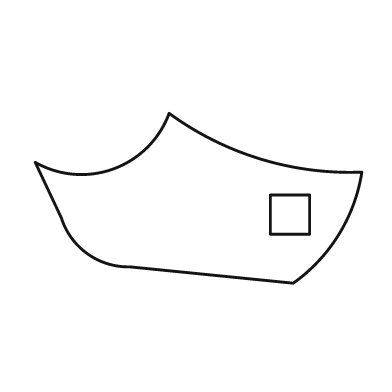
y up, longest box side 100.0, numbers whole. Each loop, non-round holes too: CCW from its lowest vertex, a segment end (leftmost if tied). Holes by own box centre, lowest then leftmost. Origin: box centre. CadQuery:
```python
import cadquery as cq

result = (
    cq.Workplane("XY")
    .moveTo(29.0, -26.0)
    .threePointArc((43.0, -11.0), (50.0, 8.0))
    .threePointArc((19.0, 12.0), (-9.0, 26.0))
    .threePointArc((-26.0, 9.0), (-50.0, 11.0))
    .lineTo(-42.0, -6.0)
    .threePointArc((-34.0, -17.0), (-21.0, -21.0))
    .close()
    .moveTo(22.0, -11.0)
    .lineTo(34.0, -11.0)
    .lineTo(34.0, 1.0)
    .lineTo(22.0, 1.0)
    .close()
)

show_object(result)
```